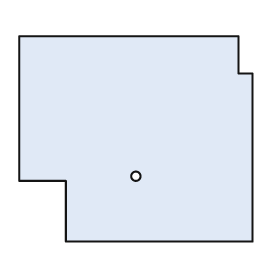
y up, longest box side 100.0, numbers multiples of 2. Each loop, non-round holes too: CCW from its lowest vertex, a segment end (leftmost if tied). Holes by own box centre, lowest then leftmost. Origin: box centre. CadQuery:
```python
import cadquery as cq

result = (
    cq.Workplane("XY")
    .moveTo(-30.0, -44.0)
    .lineTo(50.0, -44.0)
    .lineTo(50.0, 28.0)
    .lineTo(44.0, 28.0)
    .lineTo(44.0, 44.0)
    .lineTo(-50.0, 44.0)
    .lineTo(-50.0, -18.0)
    .lineTo(-30.0, -18.0)
    .close()
    .moveTo(0.0, -16.0)
    .circle(2.0)
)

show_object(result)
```